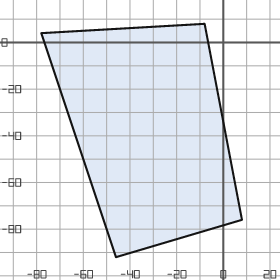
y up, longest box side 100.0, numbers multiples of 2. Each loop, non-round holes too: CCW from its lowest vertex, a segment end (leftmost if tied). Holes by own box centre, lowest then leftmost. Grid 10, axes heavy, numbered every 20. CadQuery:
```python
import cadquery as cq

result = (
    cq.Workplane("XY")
    .moveTo(-46.0, -92.0)
    .lineTo(8.0, -76.0)
    .lineTo(-8.0, 8.0)
    .lineTo(-78.0, 4.0)
    .close()
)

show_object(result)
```